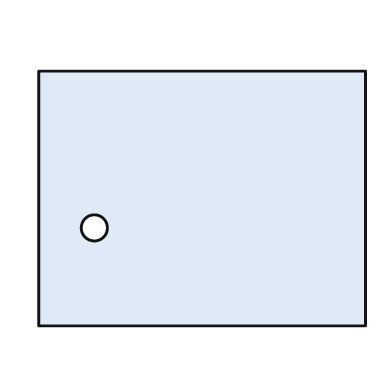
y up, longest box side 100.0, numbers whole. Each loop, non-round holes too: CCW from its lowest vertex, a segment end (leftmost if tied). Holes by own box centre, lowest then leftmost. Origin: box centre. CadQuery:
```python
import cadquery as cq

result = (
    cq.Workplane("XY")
    .moveTo(-50.0, -39.0)
    .lineTo(50.0, -39.0)
    .lineTo(50.0, 39.0)
    .lineTo(-50.0, 39.0)
    .close()
    .moveTo(-33.0, -9.0)
    .circle(4.0)
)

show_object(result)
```